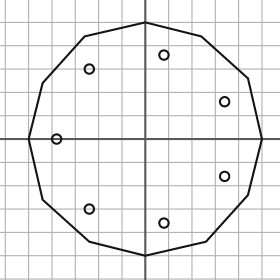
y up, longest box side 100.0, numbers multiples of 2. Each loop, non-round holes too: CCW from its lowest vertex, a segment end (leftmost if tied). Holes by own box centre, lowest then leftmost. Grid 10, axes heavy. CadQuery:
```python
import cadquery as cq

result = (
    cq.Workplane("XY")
    .moveTo(0.0, -50.0)
    .lineTo(26.0, -44.0)
    .lineTo(44.0, -24.0)
    .lineTo(50.0, 0.0)
    .lineTo(44.0, 26.0)
    .lineTo(24.0, 44.0)
    .lineTo(0.0, 50.0)
    .lineTo(-26.0, 44.0)
    .lineTo(-44.0, 24.0)
    .lineTo(-50.0, 0.0)
    .lineTo(-44.0, -26.0)
    .lineTo(-24.0, -44.0)
    .close()
    .moveTo(8.0, -36.0)
    .circle(2.0)
    .moveTo(-24.0, -30.0)
    .circle(2.0)
    .moveTo(34.0, -16.0)
    .circle(2.0)
    .moveTo(-38.0, 0.0)
    .circle(2.0)
    .moveTo(34.0, 16.0)
    .circle(2.0)
    .moveTo(-24.0, 30.0)
    .circle(2.0)
    .moveTo(8.0, 36.0)
    .circle(2.0)
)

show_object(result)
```